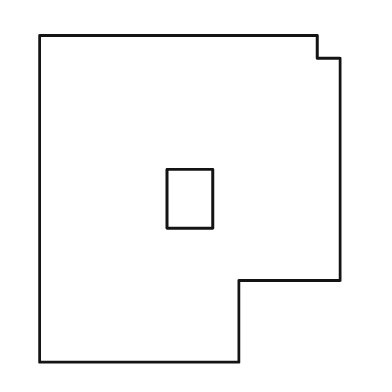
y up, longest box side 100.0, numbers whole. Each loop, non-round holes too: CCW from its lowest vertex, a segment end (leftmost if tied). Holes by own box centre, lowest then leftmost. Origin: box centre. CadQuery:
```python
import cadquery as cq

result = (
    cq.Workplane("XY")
    .moveTo(-46.0, -50.0)
    .lineTo(15.0, -50.0)
    .lineTo(15.0, -25.0)
    .lineTo(46.0, -25.0)
    .lineTo(46.0, 43.0)
    .lineTo(39.0, 43.0)
    .lineTo(39.0, 50.0)
    .lineTo(-46.0, 50.0)
    .close()
    .moveTo(-7.0, -9.0)
    .lineTo(7.0, -9.0)
    .lineTo(7.0, 9.0)
    .lineTo(-7.0, 9.0)
    .close()
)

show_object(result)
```